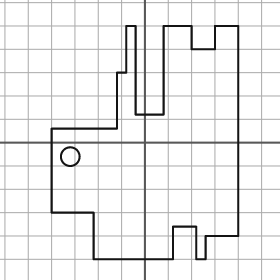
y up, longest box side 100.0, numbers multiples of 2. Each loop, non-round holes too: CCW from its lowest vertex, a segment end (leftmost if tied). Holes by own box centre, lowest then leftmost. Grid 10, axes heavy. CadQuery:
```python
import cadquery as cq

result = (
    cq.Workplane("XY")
    .moveTo(-22.0, -50.0)
    .lineTo(12.0, -50.0)
    .lineTo(12.0, -36.0)
    .lineTo(22.0, -36.0)
    .lineTo(22.0, -50.0)
    .lineTo(26.0, -50.0)
    .lineTo(26.0, -40.0)
    .lineTo(40.0, -40.0)
    .lineTo(40.0, 50.0)
    .lineTo(30.0, 50.0)
    .lineTo(30.0, 40.0)
    .lineTo(20.0, 40.0)
    .lineTo(20.0, 50.0)
    .lineTo(8.0, 50.0)
    .lineTo(8.0, 12.0)
    .lineTo(-4.0, 12.0)
    .lineTo(-4.0, 50.0)
    .lineTo(-8.0, 50.0)
    .lineTo(-8.0, 30.0)
    .lineTo(-12.0, 30.0)
    .lineTo(-12.0, 6.0)
    .lineTo(-40.0, 6.0)
    .lineTo(-40.0, -30.0)
    .lineTo(-22.0, -30.0)
    .close()
    .moveTo(-32.0, -6.0)
    .circle(4.0)
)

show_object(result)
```